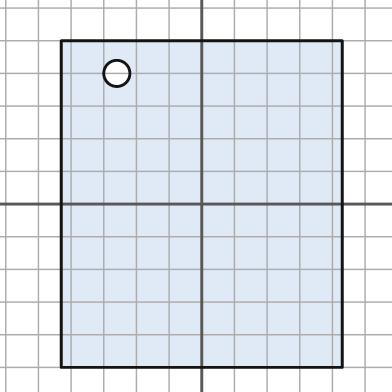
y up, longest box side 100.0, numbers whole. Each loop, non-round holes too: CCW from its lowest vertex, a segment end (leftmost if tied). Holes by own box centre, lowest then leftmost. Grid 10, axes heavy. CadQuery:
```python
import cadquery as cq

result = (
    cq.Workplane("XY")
    .moveTo(-43.0, -50.0)
    .lineTo(43.0, -50.0)
    .lineTo(43.0, 50.0)
    .lineTo(-43.0, 50.0)
    .close()
    .moveTo(-26.0, 40.0)
    .circle(4.0)
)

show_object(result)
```